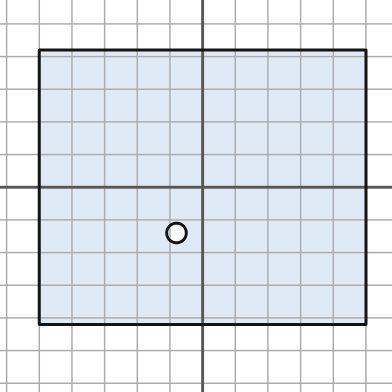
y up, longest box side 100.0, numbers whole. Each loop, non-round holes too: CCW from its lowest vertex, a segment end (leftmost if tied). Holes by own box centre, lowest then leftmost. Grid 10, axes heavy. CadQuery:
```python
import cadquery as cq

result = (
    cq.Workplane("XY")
    .moveTo(-50.0, -42.0)
    .lineTo(50.0, -42.0)
    .lineTo(50.0, 42.0)
    .lineTo(-50.0, 42.0)
    .close()
    .moveTo(-8.0, -14.0)
    .circle(3.0)
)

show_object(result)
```